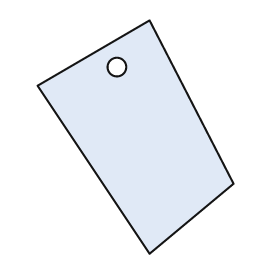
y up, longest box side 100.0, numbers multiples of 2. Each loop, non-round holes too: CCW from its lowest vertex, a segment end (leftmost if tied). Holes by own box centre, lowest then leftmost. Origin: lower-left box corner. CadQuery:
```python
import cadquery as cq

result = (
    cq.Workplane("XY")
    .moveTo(48.0, 0.0)
    .lineTo(84.0, 30.0)
    .lineTo(48.0, 100.0)
    .lineTo(0.0, 72.0)
    .close()
    .moveTo(34.0, 80.0)
    .circle(4.0)
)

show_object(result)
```